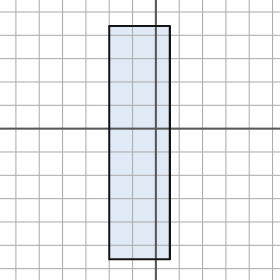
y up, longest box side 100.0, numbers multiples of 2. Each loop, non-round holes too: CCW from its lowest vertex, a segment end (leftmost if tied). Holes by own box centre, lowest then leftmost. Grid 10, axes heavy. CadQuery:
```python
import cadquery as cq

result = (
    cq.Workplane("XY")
    .moveTo(-20.0, -56.0)
    .lineTo(6.0, -56.0)
    .lineTo(6.0, 44.0)
    .lineTo(-20.0, 44.0)
    .close()
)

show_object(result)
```